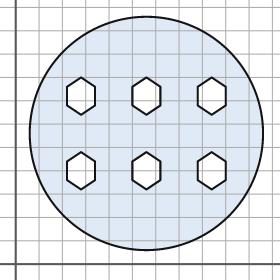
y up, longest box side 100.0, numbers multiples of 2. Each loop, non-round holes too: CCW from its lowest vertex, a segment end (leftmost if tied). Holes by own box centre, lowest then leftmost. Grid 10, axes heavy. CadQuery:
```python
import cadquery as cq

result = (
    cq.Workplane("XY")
    .moveTo(56.0, 56.0)
    .circle(50.0)
    .moveTo(28.0, 32.0)
    .lineTo(34.0, 36.0)
    .lineTo(34.0, 44.0)
    .lineTo(28.0, 48.0)
    .lineTo(22.0, 44.0)
    .lineTo(22.0, 36.0)
    .close()
    .moveTo(56.0, 32.0)
    .lineTo(62.0, 36.0)
    .lineTo(62.0, 44.0)
    .lineTo(56.0, 48.0)
    .lineTo(50.0, 44.0)
    .lineTo(50.0, 36.0)
    .close()
    .moveTo(84.0, 32.0)
    .lineTo(90.0, 36.0)
    .lineTo(90.0, 44.0)
    .lineTo(84.0, 48.0)
    .lineTo(78.0, 44.0)
    .lineTo(78.0, 36.0)
    .close()
    .moveTo(28.0, 64.0)
    .lineTo(34.0, 68.0)
    .lineTo(34.0, 76.0)
    .lineTo(28.0, 80.0)
    .lineTo(22.0, 76.0)
    .lineTo(22.0, 68.0)
    .close()
    .moveTo(56.0, 64.0)
    .lineTo(62.0, 68.0)
    .lineTo(62.0, 76.0)
    .lineTo(56.0, 80.0)
    .lineTo(50.0, 76.0)
    .lineTo(50.0, 68.0)
    .close()
    .moveTo(84.0, 64.0)
    .lineTo(90.0, 68.0)
    .lineTo(90.0, 76.0)
    .lineTo(84.0, 80.0)
    .lineTo(78.0, 76.0)
    .lineTo(78.0, 68.0)
    .close()
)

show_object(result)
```